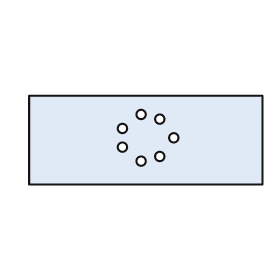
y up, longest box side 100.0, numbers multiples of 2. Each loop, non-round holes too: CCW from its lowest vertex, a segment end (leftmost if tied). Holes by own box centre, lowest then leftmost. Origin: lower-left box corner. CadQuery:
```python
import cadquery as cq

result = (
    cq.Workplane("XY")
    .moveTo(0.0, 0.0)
    .lineTo(100.0, 0.0)
    .lineTo(100.0, 38.0)
    .lineTo(0.0, 38.0)
    .close()
    .moveTo(48.0, 10.0)
    .circle(2.0)
    .moveTo(56.0, 12.0)
    .circle(2.0)
    .moveTo(40.0, 16.0)
    .circle(2.0)
    .moveTo(62.0, 20.0)
    .circle(2.0)
    .moveTo(40.0, 24.0)
    .circle(2.0)
    .moveTo(56.0, 28.0)
    .circle(2.0)
    .moveTo(48.0, 30.0)
    .circle(2.0)
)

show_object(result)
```